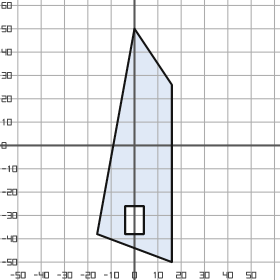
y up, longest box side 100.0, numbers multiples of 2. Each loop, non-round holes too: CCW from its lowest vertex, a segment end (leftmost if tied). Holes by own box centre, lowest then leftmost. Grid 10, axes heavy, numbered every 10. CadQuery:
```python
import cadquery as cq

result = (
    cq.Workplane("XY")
    .moveTo(16.0, -50.0)
    .lineTo(16.0, 26.0)
    .lineTo(0.0, 50.0)
    .lineTo(-16.0, -38.0)
    .close()
    .moveTo(-4.0, -38.0)
    .lineTo(4.0, -38.0)
    .lineTo(4.0, -26.0)
    .lineTo(-4.0, -26.0)
    .close()
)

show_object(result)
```